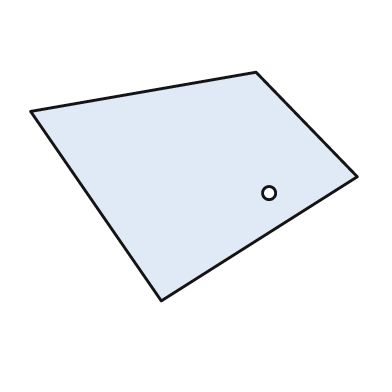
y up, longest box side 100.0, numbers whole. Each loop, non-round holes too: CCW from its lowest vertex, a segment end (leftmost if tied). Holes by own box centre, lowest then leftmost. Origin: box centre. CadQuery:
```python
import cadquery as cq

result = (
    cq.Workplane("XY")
    .moveTo(-10.0, -35.0)
    .lineTo(50.0, 3.0)
    .lineTo(19.0, 35.0)
    .lineTo(-50.0, 23.0)
    .close()
    .moveTo(23.0, -2.0)
    .circle(2.0)
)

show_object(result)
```